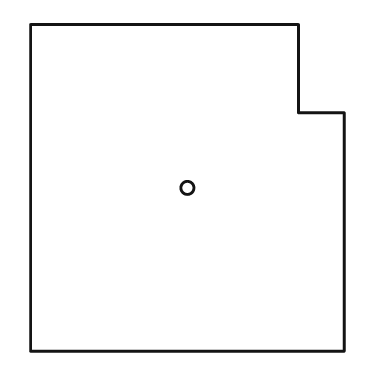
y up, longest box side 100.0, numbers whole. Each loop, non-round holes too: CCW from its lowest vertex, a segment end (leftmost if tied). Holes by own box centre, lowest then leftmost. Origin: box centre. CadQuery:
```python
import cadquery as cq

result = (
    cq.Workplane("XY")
    .moveTo(-48.0, -50.0)
    .lineTo(48.0, -50.0)
    .lineTo(48.0, 23.0)
    .lineTo(34.0, 23.0)
    .lineTo(34.0, 50.0)
    .lineTo(-48.0, 50.0)
    .close()
    .moveTo(0.0, 0.0)
    .circle(2.0)
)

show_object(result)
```